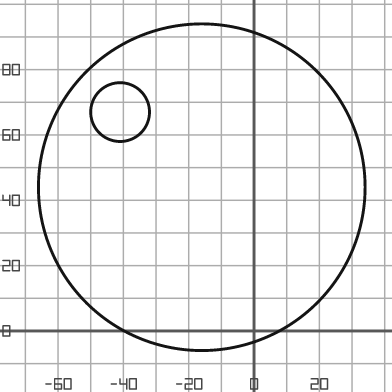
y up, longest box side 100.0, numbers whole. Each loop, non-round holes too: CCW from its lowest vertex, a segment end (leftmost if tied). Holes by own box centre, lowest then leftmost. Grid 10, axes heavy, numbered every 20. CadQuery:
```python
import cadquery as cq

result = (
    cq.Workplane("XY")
    .moveTo(-16.0, 44.0)
    .circle(50.0)
    .moveTo(-41.0, 67.0)
    .circle(9.0)
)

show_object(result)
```